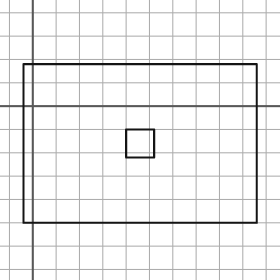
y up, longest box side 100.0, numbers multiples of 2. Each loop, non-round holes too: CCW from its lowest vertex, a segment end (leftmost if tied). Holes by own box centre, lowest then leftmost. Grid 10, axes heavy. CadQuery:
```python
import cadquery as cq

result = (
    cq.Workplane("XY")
    .moveTo(-4.0, -50.0)
    .lineTo(96.0, -50.0)
    .lineTo(96.0, 18.0)
    .lineTo(-4.0, 18.0)
    .close()
    .moveTo(40.0, -22.0)
    .lineTo(52.0, -22.0)
    .lineTo(52.0, -10.0)
    .lineTo(40.0, -10.0)
    .close()
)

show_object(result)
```